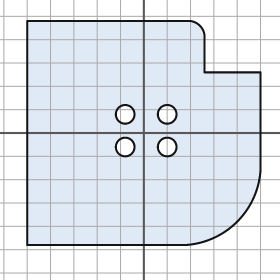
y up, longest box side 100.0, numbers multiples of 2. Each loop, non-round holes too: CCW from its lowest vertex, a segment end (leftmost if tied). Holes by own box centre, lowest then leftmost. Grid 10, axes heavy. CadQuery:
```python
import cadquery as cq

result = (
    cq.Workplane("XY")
    .moveTo(-50.0, -48.0)
    .lineTo(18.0, -48.0)
    .threePointArc((40.0, -38.0), (50.0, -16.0))
    .lineTo(50.0, 26.0)
    .lineTo(26.0, 26.0)
    .lineTo(26.0, 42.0)
    .threePointArc((24.0, 46.0), (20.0, 48.0))
    .lineTo(-50.0, 48.0)
    .close()
    .moveTo(-8.0, -6.0)
    .circle(4.0)
    .moveTo(10.0, -6.0)
    .circle(4.0)
    .moveTo(-8.0, 8.0)
    .circle(4.0)
    .moveTo(10.0, 8.0)
    .circle(4.0)
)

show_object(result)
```